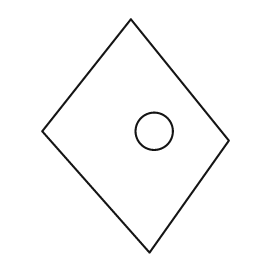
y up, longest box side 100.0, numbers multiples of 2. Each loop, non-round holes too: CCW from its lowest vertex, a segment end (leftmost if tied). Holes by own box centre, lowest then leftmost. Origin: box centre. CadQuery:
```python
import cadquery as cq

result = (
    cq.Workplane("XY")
    .moveTo(6.0, -50.0)
    .lineTo(40.0, -2.0)
    .lineTo(-2.0, 50.0)
    .lineTo(-40.0, 2.0)
    .close()
    .moveTo(8.0, 2.0)
    .circle(8.0)
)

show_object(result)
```